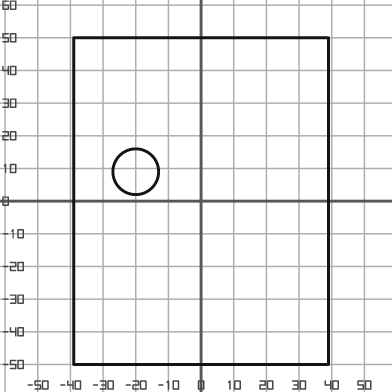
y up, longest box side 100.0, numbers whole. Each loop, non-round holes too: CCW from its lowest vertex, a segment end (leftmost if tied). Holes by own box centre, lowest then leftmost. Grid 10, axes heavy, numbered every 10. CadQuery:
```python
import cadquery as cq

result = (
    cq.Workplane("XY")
    .moveTo(-39.0, -50.0)
    .lineTo(39.0, -50.0)
    .lineTo(39.0, 50.0)
    .lineTo(-39.0, 50.0)
    .close()
    .moveTo(-20.0, 9.0)
    .circle(7.0)
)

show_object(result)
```